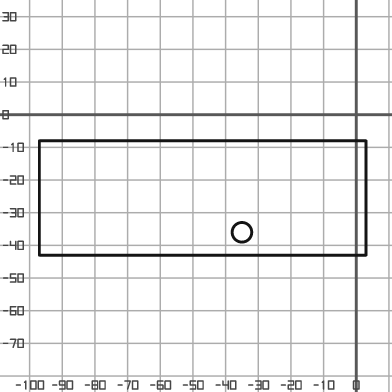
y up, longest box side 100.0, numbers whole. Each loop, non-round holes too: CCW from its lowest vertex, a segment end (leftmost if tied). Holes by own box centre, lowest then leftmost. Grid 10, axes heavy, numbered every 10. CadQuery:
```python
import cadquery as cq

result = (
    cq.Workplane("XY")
    .moveTo(-97.0, -43.0)
    .lineTo(3.0, -43.0)
    .lineTo(3.0, -8.0)
    .lineTo(-97.0, -8.0)
    .close()
    .moveTo(-35.0, -36.0)
    .circle(3.0)
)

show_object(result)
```